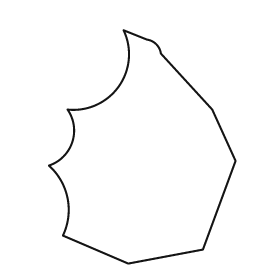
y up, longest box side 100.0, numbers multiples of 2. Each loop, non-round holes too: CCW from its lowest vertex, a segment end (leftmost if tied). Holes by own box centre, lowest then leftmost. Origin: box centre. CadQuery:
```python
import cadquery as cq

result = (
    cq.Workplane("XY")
    .moveTo(-6.0, -50.0)
    .lineTo(26.0, -44.0)
    .lineTo(40.0, -6.0)
    .lineTo(30.0, 16.0)
    .lineTo(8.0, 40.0)
    .threePointArc((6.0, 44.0), (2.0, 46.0))
    .lineTo(-8.0, 50.0)
    .threePointArc((-10.0, 26.0), (-32.0, 16.0))
    .threePointArc((-30.0, 2.0), (-40.0, -8.0))
    .threePointArc((-32.0, -22.0), (-34.0, -38.0))
    .close()
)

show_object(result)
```